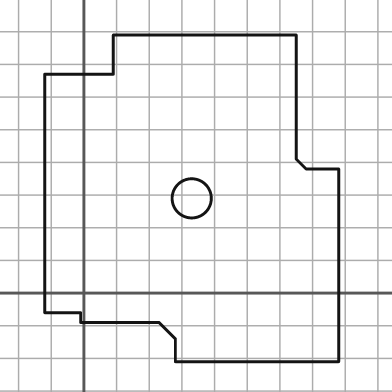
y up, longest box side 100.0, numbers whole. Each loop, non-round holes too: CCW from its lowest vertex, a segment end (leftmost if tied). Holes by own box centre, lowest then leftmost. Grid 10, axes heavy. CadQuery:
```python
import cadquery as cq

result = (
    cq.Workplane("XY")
    .moveTo(28.0, -21.0)
    .lineTo(78.0, -21.0)
    .lineTo(78.0, 38.0)
    .lineTo(68.0, 38.0)
    .lineTo(65.0, 41.0)
    .lineTo(65.0, 79.0)
    .lineTo(9.0, 79.0)
    .lineTo(9.0, 67.0)
    .lineTo(-12.0, 67.0)
    .lineTo(-12.0, -6.0)
    .lineTo(-1.0, -6.0)
    .lineTo(-1.0, -9.0)
    .lineTo(23.0, -9.0)
    .lineTo(28.0, -14.0)
    .close()
    .moveTo(33.0, 29.0)
    .circle(6.0)
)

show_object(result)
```